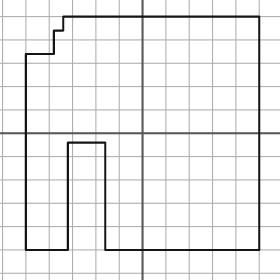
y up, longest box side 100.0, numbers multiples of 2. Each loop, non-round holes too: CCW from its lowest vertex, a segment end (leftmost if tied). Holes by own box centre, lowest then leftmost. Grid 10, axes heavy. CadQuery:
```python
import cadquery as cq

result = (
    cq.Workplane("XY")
    .moveTo(-50.0, -50.0)
    .lineTo(-32.0, -50.0)
    .lineTo(-32.0, -4.0)
    .lineTo(-16.0, -4.0)
    .lineTo(-16.0, -50.0)
    .lineTo(50.0, -50.0)
    .lineTo(50.0, 50.0)
    .lineTo(-34.0, 50.0)
    .lineTo(-34.0, 44.0)
    .lineTo(-38.0, 44.0)
    .lineTo(-38.0, 34.0)
    .lineTo(-50.0, 34.0)
    .close()
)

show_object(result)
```